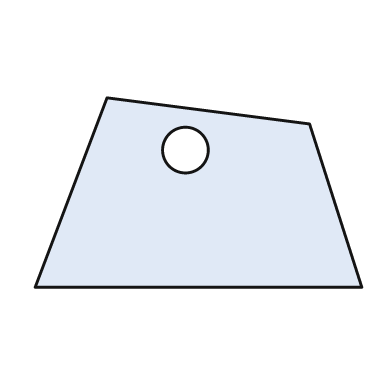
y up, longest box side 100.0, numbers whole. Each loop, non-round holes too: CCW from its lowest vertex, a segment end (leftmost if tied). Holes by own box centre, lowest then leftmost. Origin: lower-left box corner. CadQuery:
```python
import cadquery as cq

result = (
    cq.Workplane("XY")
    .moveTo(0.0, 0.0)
    .lineTo(100.0, 0.0)
    .lineTo(84.0, 50.0)
    .lineTo(22.0, 58.0)
    .close()
    .moveTo(46.0, 42.0)
    .circle(7.0)
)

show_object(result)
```